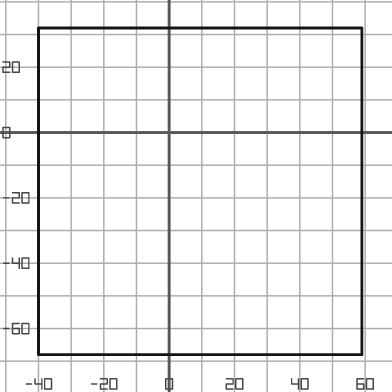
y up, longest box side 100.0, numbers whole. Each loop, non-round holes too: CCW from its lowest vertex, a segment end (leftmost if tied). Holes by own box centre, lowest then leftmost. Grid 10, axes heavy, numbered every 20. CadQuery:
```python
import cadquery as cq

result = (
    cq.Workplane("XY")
    .moveTo(-40.0, -68.0)
    .lineTo(59.0, -68.0)
    .lineTo(59.0, 32.0)
    .lineTo(-40.0, 32.0)
    .close()
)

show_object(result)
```